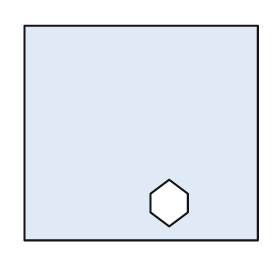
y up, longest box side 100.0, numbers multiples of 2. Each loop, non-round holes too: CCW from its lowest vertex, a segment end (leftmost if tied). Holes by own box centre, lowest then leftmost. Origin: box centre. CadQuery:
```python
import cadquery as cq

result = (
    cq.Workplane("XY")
    .moveTo(-50.0, -46.0)
    .lineTo(50.0, -46.0)
    .lineTo(50.0, 46.0)
    .lineTo(-50.0, 46.0)
    .close()
    .moveTo(12.0, -40.0)
    .lineTo(20.0, -34.0)
    .lineTo(20.0, -26.0)
    .lineTo(12.0, -20.0)
    .lineTo(4.0, -26.0)
    .lineTo(4.0, -34.0)
    .close()
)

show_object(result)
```